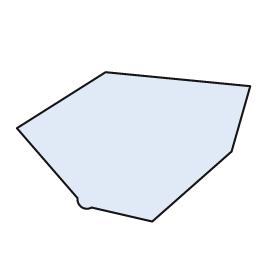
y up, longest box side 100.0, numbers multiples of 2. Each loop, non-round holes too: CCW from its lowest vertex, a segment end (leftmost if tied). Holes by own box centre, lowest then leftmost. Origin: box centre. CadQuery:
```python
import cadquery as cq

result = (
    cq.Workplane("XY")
    .moveTo(8.0, -32.0)
    .lineTo(42.0, -2.0)
    .lineTo(50.0, 26.0)
    .lineTo(-12.0, 32.0)
    .lineTo(-50.0, 8.0)
    .lineTo(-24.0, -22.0)
    .threePointArc((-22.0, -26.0), (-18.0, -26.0))
    .close()
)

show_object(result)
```